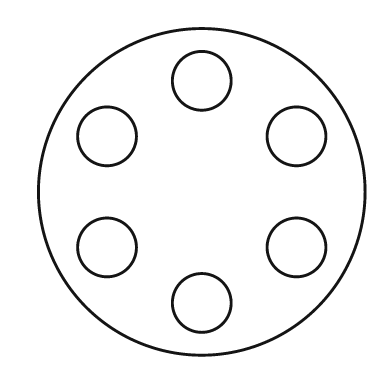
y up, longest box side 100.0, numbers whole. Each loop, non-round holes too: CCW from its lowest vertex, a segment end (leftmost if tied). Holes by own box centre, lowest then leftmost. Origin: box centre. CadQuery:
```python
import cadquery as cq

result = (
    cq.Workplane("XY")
    .moveTo(0.0, 0.0)
    .circle(50.0)
    .moveTo(0.0, -34.0)
    .circle(9.0)
    .moveTo(-29.0, -17.0)
    .circle(9.0)
    .moveTo(29.0, -17.0)
    .circle(9.0)
    .moveTo(-29.0, 17.0)
    .circle(9.0)
    .moveTo(29.0, 17.0)
    .circle(9.0)
    .moveTo(0.0, 34.0)
    .circle(9.0)
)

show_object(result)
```